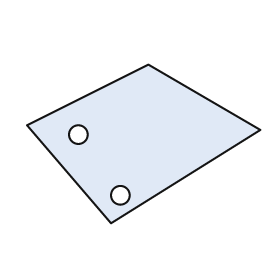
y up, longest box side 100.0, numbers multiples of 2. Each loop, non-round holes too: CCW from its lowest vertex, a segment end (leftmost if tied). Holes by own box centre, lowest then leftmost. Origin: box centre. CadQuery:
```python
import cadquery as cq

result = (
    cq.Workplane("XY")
    .moveTo(-14.0, -34.0)
    .lineTo(50.0, 6.0)
    .lineTo(2.0, 34.0)
    .lineTo(-50.0, 8.0)
    .close()
    .moveTo(-10.0, -22.0)
    .circle(4.0)
    .moveTo(-28.0, 4.0)
    .circle(4.0)
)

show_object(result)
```